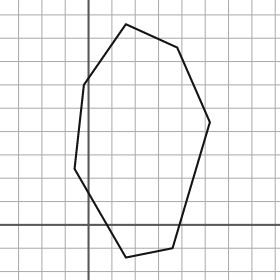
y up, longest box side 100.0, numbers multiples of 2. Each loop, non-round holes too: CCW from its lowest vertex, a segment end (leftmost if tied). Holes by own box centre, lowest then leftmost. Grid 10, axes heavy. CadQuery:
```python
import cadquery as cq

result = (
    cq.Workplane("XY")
    .moveTo(16.0, -14.0)
    .lineTo(36.0, -10.0)
    .lineTo(52.0, 44.0)
    .lineTo(38.0, 76.0)
    .lineTo(16.0, 86.0)
    .lineTo(-2.0, 60.0)
    .lineTo(-6.0, 24.0)
    .close()
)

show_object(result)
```